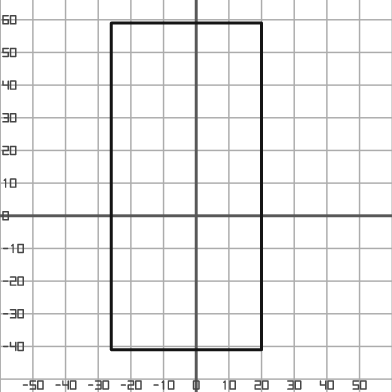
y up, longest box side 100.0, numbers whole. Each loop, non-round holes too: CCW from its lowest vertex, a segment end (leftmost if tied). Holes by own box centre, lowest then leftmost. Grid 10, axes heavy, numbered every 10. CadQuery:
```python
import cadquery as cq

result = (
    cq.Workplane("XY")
    .moveTo(-26.0, -41.0)
    .lineTo(20.0, -41.0)
    .lineTo(20.0, 59.0)
    .lineTo(-26.0, 59.0)
    .close()
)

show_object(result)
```